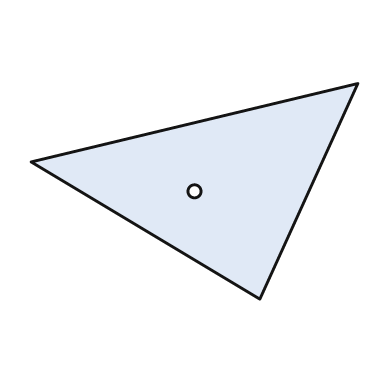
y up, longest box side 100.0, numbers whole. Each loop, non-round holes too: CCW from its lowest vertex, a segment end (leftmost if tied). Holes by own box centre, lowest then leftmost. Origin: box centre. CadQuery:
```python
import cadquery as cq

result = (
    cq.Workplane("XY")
    .moveTo(20.0, -33.0)
    .lineTo(50.0, 33.0)
    .lineTo(-50.0, 9.0)
    .close()
    .moveTo(0.0, 0.0)
    .circle(2.0)
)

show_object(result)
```